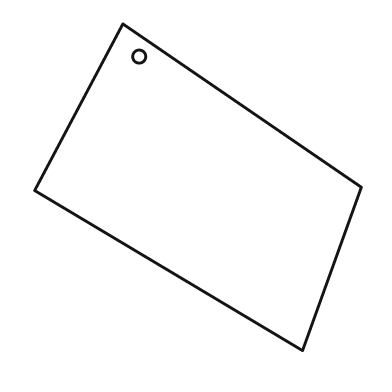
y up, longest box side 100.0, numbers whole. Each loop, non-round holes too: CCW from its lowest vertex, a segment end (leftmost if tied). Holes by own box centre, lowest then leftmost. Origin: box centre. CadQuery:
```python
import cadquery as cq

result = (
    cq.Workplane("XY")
    .moveTo(32.0, -50.0)
    .lineTo(50.0, 0.0)
    .lineTo(-23.0, 50.0)
    .lineTo(-50.0, -1.0)
    .close()
    .moveTo(-18.0, 40.0)
    .circle(2.0)
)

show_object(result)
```